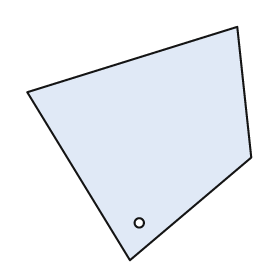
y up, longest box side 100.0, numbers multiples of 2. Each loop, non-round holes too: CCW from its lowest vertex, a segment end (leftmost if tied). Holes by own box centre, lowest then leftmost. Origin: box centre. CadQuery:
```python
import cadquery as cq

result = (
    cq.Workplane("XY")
    .moveTo(-4.0, -50.0)
    .lineTo(48.0, -6.0)
    .lineTo(42.0, 50.0)
    .lineTo(-48.0, 22.0)
    .close()
    .moveTo(0.0, -34.0)
    .circle(2.0)
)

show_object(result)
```